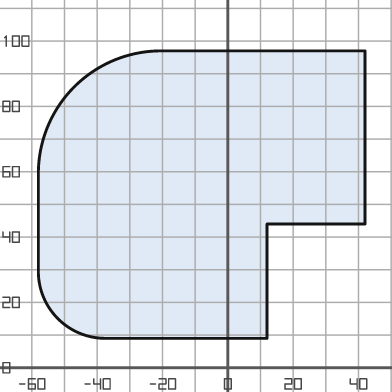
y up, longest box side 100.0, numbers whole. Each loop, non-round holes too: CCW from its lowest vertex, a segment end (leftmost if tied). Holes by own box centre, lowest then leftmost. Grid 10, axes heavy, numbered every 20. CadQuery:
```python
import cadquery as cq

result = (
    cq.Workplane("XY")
    .moveTo(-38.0, 9.0)
    .lineTo(12.0, 9.0)
    .lineTo(12.0, 44.0)
    .lineTo(42.0, 44.0)
    .lineTo(42.0, 97.0)
    .lineTo(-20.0, 97.0)
    .threePointArc((-47.0, 86.0), (-58.0, 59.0))
    .lineTo(-58.0, 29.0)
    .threePointArc((-52.0, 15.0), (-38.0, 9.0))
    .close()
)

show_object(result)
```